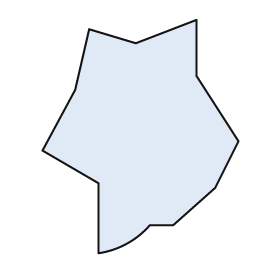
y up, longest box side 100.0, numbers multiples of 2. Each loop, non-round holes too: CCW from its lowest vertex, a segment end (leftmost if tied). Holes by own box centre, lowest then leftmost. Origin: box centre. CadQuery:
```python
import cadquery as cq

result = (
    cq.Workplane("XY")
    .moveTo(-18.0, -50.0)
    .threePointArc((-6.0, -46.0), (4.0, -38.0))
    .lineTo(14.0, -38.0)
    .lineTo(32.0, -22.0)
    .lineTo(42.0, -2.0)
    .lineTo(24.0, 26.0)
    .lineTo(24.0, 50.0)
    .lineTo(-2.0, 40.0)
    .lineTo(-22.0, 46.0)
    .lineTo(-28.0, 20.0)
    .lineTo(-42.0, -6.0)
    .lineTo(-18.0, -20.0)
    .close()
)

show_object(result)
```